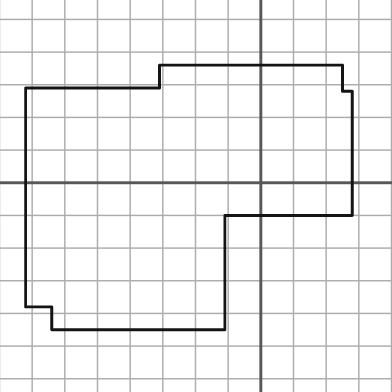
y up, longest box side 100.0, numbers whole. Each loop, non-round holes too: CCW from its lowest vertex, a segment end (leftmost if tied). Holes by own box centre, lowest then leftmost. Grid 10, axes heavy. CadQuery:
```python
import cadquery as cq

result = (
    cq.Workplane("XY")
    .moveTo(-64.0, -45.0)
    .lineTo(-11.0, -45.0)
    .lineTo(-11.0, -10.0)
    .lineTo(28.0, -10.0)
    .lineTo(28.0, 28.0)
    .lineTo(25.0, 28.0)
    .lineTo(25.0, 36.0)
    .lineTo(-31.0, 36.0)
    .lineTo(-31.0, 29.0)
    .lineTo(-72.0, 29.0)
    .lineTo(-72.0, -38.0)
    .lineTo(-64.0, -38.0)
    .close()
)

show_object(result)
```